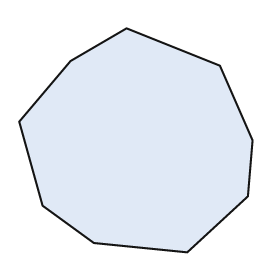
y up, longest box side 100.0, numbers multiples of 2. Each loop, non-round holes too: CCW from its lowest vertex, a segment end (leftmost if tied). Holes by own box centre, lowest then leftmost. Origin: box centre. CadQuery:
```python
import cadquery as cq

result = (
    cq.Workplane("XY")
    .moveTo(22.0, -48.0)
    .lineTo(48.0, -24.0)
    .lineTo(50.0, 0.0)
    .lineTo(36.0, 32.0)
    .lineTo(-4.0, 48.0)
    .lineTo(-28.0, 34.0)
    .lineTo(-50.0, 8.0)
    .lineTo(-40.0, -28.0)
    .lineTo(-18.0, -44.0)
    .close()
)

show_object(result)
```